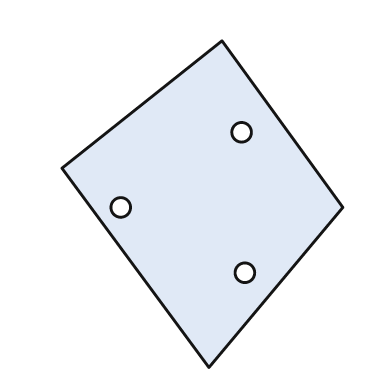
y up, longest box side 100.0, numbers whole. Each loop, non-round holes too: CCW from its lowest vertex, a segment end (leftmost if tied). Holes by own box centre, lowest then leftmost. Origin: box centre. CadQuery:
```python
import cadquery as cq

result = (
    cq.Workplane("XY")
    .moveTo(2.0, -50.0)
    .lineTo(43.0, -1.0)
    .lineTo(6.0, 50.0)
    .lineTo(-43.0, 11.0)
    .close()
    .moveTo(13.0, -21.0)
    .circle(3.0)
    .moveTo(-25.0, -1.0)
    .circle(3.0)
    .moveTo(12.0, 22.0)
    .circle(3.0)
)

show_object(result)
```